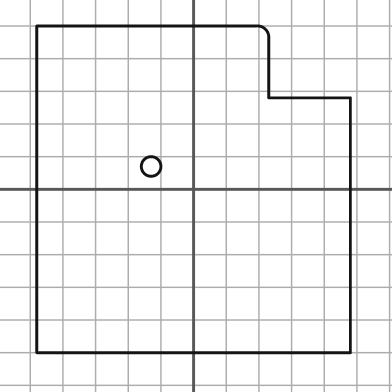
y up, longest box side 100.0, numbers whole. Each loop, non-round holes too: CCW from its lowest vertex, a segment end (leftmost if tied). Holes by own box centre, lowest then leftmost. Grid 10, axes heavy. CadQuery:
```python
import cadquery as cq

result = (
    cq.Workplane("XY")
    .moveTo(-48.0, -50.0)
    .lineTo(48.0, -50.0)
    .lineTo(48.0, 28.0)
    .lineTo(23.0, 28.0)
    .lineTo(23.0, 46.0)
    .threePointArc((22.0, 49.0), (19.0, 50.0))
    .lineTo(-48.0, 50.0)
    .close()
    .moveTo(-13.0, 7.0)
    .circle(3.0)
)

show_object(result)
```